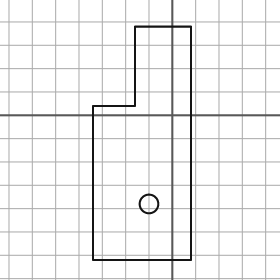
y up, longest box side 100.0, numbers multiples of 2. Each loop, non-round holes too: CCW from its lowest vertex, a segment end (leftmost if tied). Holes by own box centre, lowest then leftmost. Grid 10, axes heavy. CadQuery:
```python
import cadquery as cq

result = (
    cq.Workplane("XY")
    .moveTo(-34.0, -62.0)
    .lineTo(8.0, -62.0)
    .lineTo(8.0, 38.0)
    .lineTo(-16.0, 38.0)
    .lineTo(-16.0, 4.0)
    .lineTo(-34.0, 4.0)
    .close()
    .moveTo(-10.0, -38.0)
    .circle(4.0)
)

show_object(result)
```